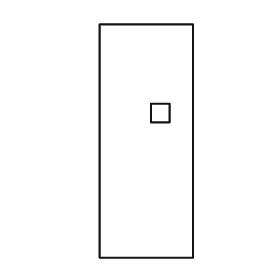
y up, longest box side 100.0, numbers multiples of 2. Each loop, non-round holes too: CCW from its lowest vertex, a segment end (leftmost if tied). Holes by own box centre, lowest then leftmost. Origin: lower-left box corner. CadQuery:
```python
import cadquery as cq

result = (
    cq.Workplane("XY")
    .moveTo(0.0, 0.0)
    .lineTo(40.0, 0.0)
    .lineTo(40.0, 100.0)
    .lineTo(0.0, 100.0)
    .close()
    .moveTo(22.0, 58.0)
    .lineTo(30.0, 58.0)
    .lineTo(30.0, 66.0)
    .lineTo(22.0, 66.0)
    .close()
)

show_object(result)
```